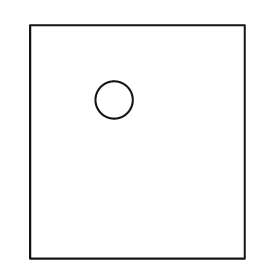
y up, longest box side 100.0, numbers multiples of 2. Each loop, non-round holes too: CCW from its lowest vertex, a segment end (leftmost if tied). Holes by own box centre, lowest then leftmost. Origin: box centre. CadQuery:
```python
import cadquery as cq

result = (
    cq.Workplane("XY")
    .moveTo(-46.0, -50.0)
    .lineTo(46.0, -50.0)
    .lineTo(46.0, 50.0)
    .lineTo(-46.0, 50.0)
    .close()
    .moveTo(-10.0, 18.0)
    .circle(8.0)
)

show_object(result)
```